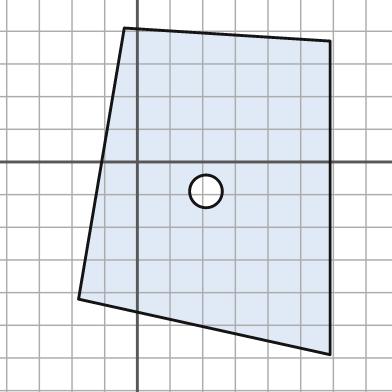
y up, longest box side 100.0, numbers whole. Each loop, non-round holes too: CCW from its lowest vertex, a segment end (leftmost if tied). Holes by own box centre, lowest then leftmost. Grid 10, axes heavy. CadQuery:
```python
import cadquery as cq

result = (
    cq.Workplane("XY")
    .moveTo(59.0, -59.0)
    .lineTo(59.0, 37.0)
    .lineTo(-4.0, 41.0)
    .lineTo(-18.0, -42.0)
    .close()
    .moveTo(21.0, -9.0)
    .circle(5.0)
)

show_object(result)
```